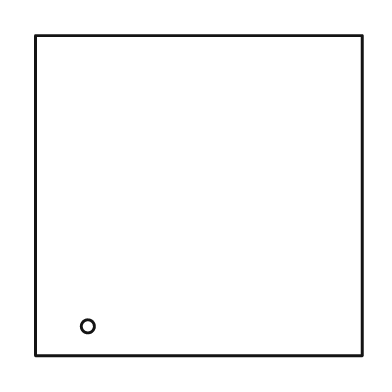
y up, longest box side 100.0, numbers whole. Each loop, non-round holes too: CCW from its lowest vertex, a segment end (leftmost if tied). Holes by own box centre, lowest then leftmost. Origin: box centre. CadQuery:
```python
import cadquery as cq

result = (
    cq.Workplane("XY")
    .moveTo(-50.0, -49.0)
    .lineTo(50.0, -49.0)
    .lineTo(50.0, 49.0)
    .lineTo(-50.0, 49.0)
    .close()
    .moveTo(-34.0, -40.0)
    .circle(2.0)
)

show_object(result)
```